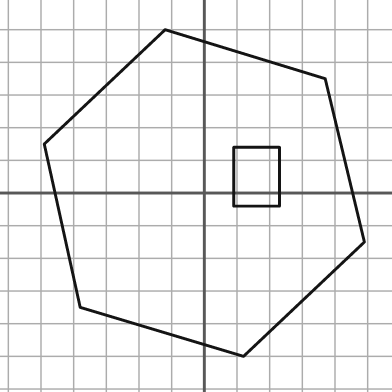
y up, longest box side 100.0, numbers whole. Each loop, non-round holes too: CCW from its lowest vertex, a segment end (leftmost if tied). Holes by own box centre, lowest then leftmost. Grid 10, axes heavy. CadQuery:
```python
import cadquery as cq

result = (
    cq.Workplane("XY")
    .moveTo(12.0, -50.0)
    .lineTo(49.0, -15.0)
    .lineTo(37.0, 35.0)
    .lineTo(-12.0, 50.0)
    .lineTo(-49.0, 15.0)
    .lineTo(-38.0, -35.0)
    .close()
    .moveTo(9.0, -4.0)
    .lineTo(23.0, -4.0)
    .lineTo(23.0, 14.0)
    .lineTo(9.0, 14.0)
    .close()
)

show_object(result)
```